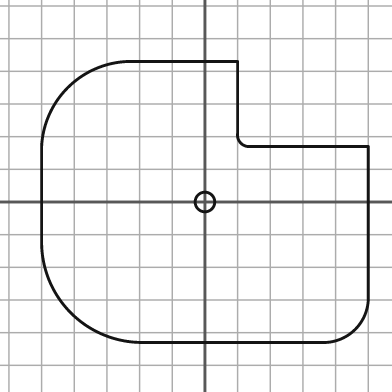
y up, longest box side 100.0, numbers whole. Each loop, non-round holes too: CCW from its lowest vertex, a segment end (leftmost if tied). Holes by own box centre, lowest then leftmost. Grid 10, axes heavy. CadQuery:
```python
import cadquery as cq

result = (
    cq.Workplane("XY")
    .moveTo(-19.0, -43.0)
    .lineTo(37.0, -43.0)
    .threePointArc((46.0, -39.0), (50.0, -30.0))
    .lineTo(50.0, 17.0)
    .lineTo(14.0, 17.0)
    .threePointArc((11.0, 18.0), (10.0, 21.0))
    .lineTo(10.0, 43.0)
    .lineTo(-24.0, 43.0)
    .threePointArc((-42.0, 35.0), (-50.0, 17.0))
    .lineTo(-50.0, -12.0)
    .threePointArc((-41.0, -34.0), (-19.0, -43.0))
    .close()
    .moveTo(0.0, 0.0)
    .circle(3.0)
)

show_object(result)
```